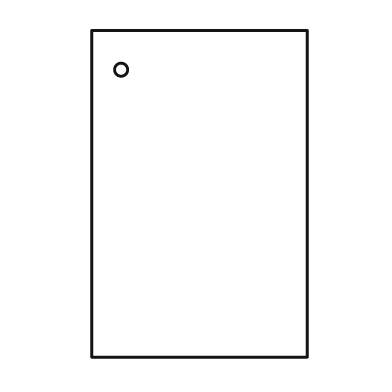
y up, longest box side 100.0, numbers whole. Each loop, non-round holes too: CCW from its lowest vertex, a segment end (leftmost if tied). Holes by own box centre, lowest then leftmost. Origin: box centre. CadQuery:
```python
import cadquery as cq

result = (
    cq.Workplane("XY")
    .moveTo(-33.0, -50.0)
    .lineTo(33.0, -50.0)
    .lineTo(33.0, 50.0)
    .lineTo(-33.0, 50.0)
    .close()
    .moveTo(-24.0, 38.0)
    .circle(2.0)
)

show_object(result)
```